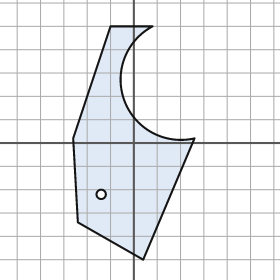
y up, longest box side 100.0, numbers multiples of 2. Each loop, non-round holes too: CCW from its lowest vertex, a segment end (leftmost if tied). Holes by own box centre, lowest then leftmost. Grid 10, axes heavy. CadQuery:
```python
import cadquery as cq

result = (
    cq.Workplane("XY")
    .moveTo(4.0, -50.0)
    .lineTo(26.0, 2.0)
    .threePointArc((-4.0, 18.0), (8.0, 50.0))
    .lineTo(-10.0, 50.0)
    .lineTo(-26.0, 2.0)
    .lineTo(-24.0, -34.0)
    .close()
    .moveTo(-14.0, -22.0)
    .circle(2.0)
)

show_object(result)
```